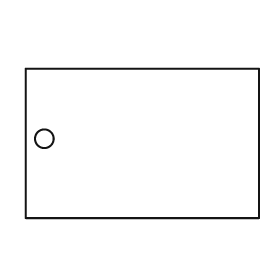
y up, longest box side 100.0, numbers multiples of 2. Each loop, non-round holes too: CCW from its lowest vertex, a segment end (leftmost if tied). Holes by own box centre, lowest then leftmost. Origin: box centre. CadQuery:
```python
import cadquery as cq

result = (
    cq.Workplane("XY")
    .moveTo(-50.0, -32.0)
    .lineTo(50.0, -32.0)
    .lineTo(50.0, 32.0)
    .lineTo(-50.0, 32.0)
    .close()
    .moveTo(-42.0, 2.0)
    .circle(4.0)
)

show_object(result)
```